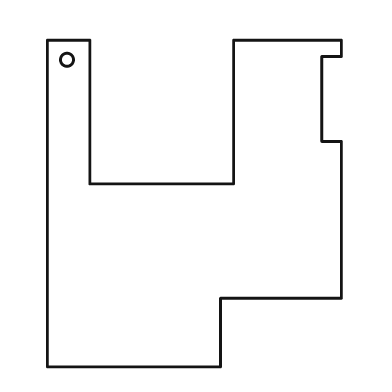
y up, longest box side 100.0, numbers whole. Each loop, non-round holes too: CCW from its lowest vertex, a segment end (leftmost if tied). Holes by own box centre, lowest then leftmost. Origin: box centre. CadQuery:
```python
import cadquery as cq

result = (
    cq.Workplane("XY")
    .moveTo(-45.0, -50.0)
    .lineTo(8.0, -50.0)
    .lineTo(8.0, -29.0)
    .lineTo(45.0, -29.0)
    .lineTo(45.0, 19.0)
    .lineTo(39.0, 19.0)
    .lineTo(39.0, 45.0)
    .lineTo(45.0, 45.0)
    .lineTo(45.0, 50.0)
    .lineTo(12.0, 50.0)
    .lineTo(12.0, 6.0)
    .lineTo(-32.0, 6.0)
    .lineTo(-32.0, 50.0)
    .lineTo(-45.0, 50.0)
    .close()
    .moveTo(-39.0, 44.0)
    .circle(2.0)
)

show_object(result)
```